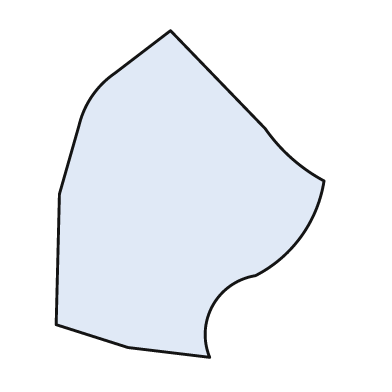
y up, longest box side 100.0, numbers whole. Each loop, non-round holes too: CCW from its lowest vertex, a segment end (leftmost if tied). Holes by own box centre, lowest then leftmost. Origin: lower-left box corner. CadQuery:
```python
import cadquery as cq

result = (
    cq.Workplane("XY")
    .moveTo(47.0, 0.0)
    .threePointArc((48.0, 16.0), (61.0, 25.0))
    .threePointArc((75.0, 37.0), (82.0, 54.0))
    .threePointArc((72.0, 61.0), (64.0, 70.0))
    .lineTo(35.0, 100.0)
    .lineTo(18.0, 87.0)
    .threePointArc((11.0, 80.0), (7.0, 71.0))
    .lineTo(1.0, 50.0)
    .lineTo(0.0, 10.0)
    .lineTo(22.0, 3.0)
    .close()
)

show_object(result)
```